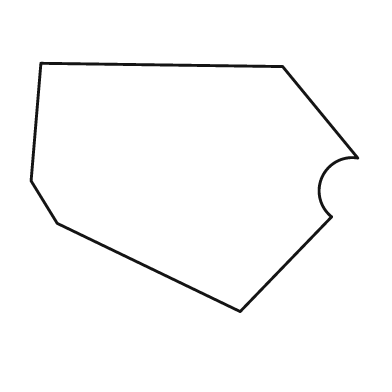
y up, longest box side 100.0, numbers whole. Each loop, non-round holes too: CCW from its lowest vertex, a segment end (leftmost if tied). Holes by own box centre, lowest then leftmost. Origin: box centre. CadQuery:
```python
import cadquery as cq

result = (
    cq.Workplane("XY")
    .moveTo(14.0, -38.0)
    .lineTo(42.0, -9.0)
    .threePointArc((39.0, 3.0), (50.0, 9.0))
    .lineTo(27.0, 37.0)
    .lineTo(-47.0, 38.0)
    .lineTo(-50.0, 2.0)
    .lineTo(-42.0, -11.0)
    .close()
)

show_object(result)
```